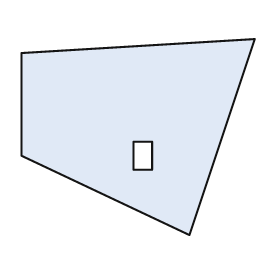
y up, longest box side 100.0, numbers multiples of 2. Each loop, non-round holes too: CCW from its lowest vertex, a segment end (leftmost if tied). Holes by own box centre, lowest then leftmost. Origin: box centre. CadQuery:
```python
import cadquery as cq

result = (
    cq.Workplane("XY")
    .moveTo(22.0, -42.0)
    .lineTo(50.0, 42.0)
    .lineTo(-50.0, 36.0)
    .lineTo(-50.0, -8.0)
    .close()
    .moveTo(-2.0, -14.0)
    .lineTo(6.0, -14.0)
    .lineTo(6.0, -2.0)
    .lineTo(-2.0, -2.0)
    .close()
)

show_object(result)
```